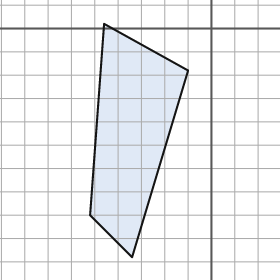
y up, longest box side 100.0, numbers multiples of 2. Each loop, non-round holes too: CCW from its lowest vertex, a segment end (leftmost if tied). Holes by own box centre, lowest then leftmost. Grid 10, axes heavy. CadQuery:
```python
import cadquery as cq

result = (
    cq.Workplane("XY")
    .moveTo(-34.0, -98.0)
    .lineTo(-10.0, -18.0)
    .lineTo(-46.0, 2.0)
    .lineTo(-52.0, -80.0)
    .close()
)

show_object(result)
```